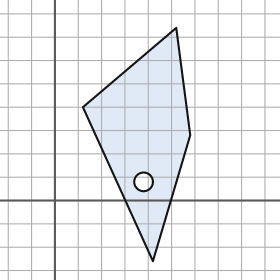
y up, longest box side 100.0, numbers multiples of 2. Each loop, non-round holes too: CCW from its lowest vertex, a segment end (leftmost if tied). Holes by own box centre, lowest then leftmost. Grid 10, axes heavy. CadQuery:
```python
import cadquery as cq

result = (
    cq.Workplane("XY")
    .moveTo(42.0, -26.0)
    .lineTo(58.0, 28.0)
    .lineTo(52.0, 74.0)
    .lineTo(12.0, 40.0)
    .close()
    .moveTo(38.0, 8.0)
    .circle(4.0)
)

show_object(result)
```